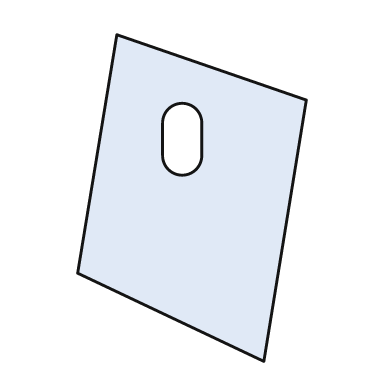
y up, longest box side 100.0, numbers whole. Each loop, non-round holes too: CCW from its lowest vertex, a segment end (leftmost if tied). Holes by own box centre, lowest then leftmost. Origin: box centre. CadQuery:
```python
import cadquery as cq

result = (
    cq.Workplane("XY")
    .moveTo(22.0, -50.0)
    .lineTo(35.0, 30.0)
    .lineTo(-23.0, 50.0)
    .lineTo(-35.0, -23.0)
    .close()
    .moveTo(-9.0, 13.0)
    .threePointArc((-3.0, 7.0), (3.0, 13.0))
    .lineTo(3.0, 23.0)
    .threePointArc((-3.0, 29.0), (-9.0, 23.0))
    .close()
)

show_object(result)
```